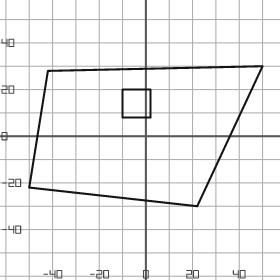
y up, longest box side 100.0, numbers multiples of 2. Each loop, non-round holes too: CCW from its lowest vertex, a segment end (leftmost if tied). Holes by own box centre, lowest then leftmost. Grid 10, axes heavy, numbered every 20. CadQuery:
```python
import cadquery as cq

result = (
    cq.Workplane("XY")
    .moveTo(22.0, -30.0)
    .lineTo(50.0, 30.0)
    .lineTo(-42.0, 28.0)
    .lineTo(-50.0, -22.0)
    .close()
    .moveTo(-10.0, 8.0)
    .lineTo(2.0, 8.0)
    .lineTo(2.0, 20.0)
    .lineTo(-10.0, 20.0)
    .close()
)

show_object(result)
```